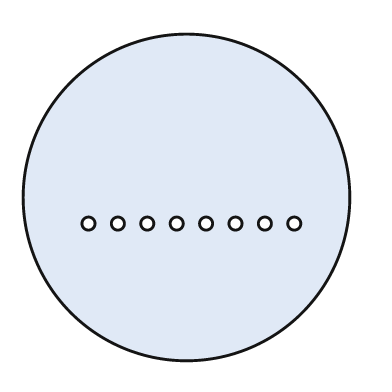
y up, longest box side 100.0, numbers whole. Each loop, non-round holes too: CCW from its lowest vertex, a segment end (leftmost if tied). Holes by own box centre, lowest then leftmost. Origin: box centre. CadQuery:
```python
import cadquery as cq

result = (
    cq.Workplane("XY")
    .moveTo(0.0, 0.0)
    .circle(50.0)
    .moveTo(-30.0, -8.0)
    .circle(2.0)
    .moveTo(-21.0, -8.0)
    .circle(2.0)
    .moveTo(-12.0, -8.0)
    .circle(2.0)
    .moveTo(-3.0, -8.0)
    .circle(2.0)
    .moveTo(6.0, -8.0)
    .circle(2.0)
    .moveTo(15.0, -8.0)
    .circle(2.0)
    .moveTo(24.0, -8.0)
    .circle(2.0)
    .moveTo(33.0, -8.0)
    .circle(2.0)
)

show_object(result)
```